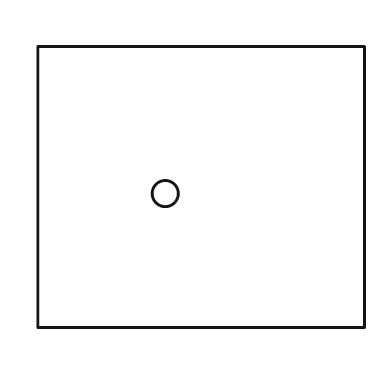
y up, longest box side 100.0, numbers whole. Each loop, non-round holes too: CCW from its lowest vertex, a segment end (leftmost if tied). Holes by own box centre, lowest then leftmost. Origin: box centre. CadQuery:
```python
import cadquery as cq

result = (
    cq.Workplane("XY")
    .moveTo(-50.0, -43.0)
    .lineTo(50.0, -43.0)
    .lineTo(50.0, 43.0)
    .lineTo(-50.0, 43.0)
    .close()
    .moveTo(-11.0, -2.0)
    .circle(4.0)
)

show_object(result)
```